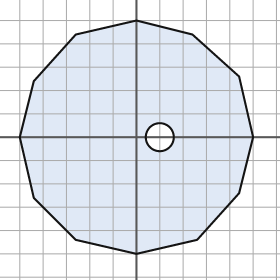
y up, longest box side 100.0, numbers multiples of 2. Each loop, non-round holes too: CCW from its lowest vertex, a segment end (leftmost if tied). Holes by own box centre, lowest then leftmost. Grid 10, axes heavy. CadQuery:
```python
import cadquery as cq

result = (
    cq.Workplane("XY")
    .moveTo(0.0, -50.0)
    .lineTo(26.0, -44.0)
    .lineTo(44.0, -24.0)
    .lineTo(50.0, 0.0)
    .lineTo(44.0, 26.0)
    .lineTo(24.0, 44.0)
    .lineTo(0.0, 50.0)
    .lineTo(-26.0, 44.0)
    .lineTo(-44.0, 24.0)
    .lineTo(-50.0, 0.0)
    .lineTo(-44.0, -26.0)
    .lineTo(-26.0, -44.0)
    .close()
    .moveTo(10.0, 0.0)
    .circle(6.0)
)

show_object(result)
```